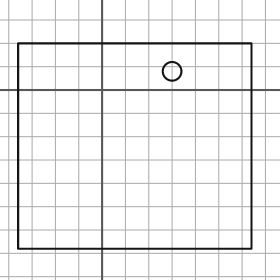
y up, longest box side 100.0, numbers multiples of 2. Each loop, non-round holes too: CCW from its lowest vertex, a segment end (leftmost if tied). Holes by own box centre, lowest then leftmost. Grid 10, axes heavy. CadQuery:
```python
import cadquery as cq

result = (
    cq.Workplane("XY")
    .moveTo(-36.0, -68.0)
    .lineTo(64.0, -68.0)
    .lineTo(64.0, 20.0)
    .lineTo(-36.0, 20.0)
    .close()
    .moveTo(30.0, 8.0)
    .circle(4.0)
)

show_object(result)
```